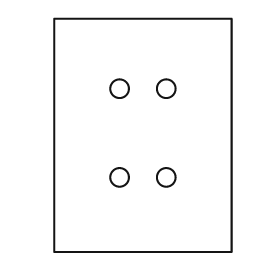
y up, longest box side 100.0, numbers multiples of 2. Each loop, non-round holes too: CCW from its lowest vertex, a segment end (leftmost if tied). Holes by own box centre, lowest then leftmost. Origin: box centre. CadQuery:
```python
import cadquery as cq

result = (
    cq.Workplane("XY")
    .moveTo(-38.0, -50.0)
    .lineTo(38.0, -50.0)
    .lineTo(38.0, 50.0)
    .lineTo(-38.0, 50.0)
    .close()
    .moveTo(-10.0, -18.0)
    .circle(4.0)
    .moveTo(10.0, -18.0)
    .circle(4.0)
    .moveTo(-10.0, 20.0)
    .circle(4.0)
    .moveTo(10.0, 20.0)
    .circle(4.0)
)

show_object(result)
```